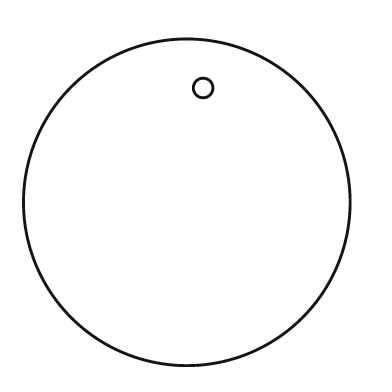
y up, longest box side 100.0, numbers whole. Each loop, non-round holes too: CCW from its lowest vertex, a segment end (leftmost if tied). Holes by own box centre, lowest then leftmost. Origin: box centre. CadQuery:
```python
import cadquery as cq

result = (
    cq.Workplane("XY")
    .moveTo(0.0, 0.0)
    .circle(50.0)
    .moveTo(5.0, 35.0)
    .circle(3.0)
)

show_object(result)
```